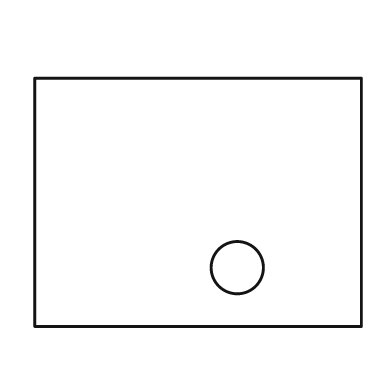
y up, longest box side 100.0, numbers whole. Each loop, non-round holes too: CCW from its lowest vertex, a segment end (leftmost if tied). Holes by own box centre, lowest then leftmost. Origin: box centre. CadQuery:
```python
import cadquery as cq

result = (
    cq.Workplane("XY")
    .moveTo(-50.0, -38.0)
    .lineTo(50.0, -38.0)
    .lineTo(50.0, 38.0)
    .lineTo(-50.0, 38.0)
    .close()
    .moveTo(12.0, -20.0)
    .circle(8.0)
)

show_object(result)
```